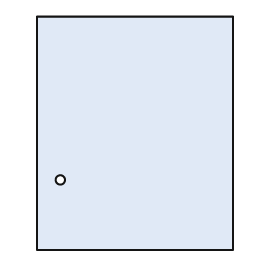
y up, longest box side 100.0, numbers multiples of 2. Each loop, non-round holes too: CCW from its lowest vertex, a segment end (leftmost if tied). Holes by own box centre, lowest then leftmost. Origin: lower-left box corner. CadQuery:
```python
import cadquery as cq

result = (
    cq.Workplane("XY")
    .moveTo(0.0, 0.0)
    .lineTo(84.0, 0.0)
    .lineTo(84.0, 100.0)
    .lineTo(0.0, 100.0)
    .close()
    .moveTo(10.0, 30.0)
    .circle(2.0)
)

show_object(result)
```